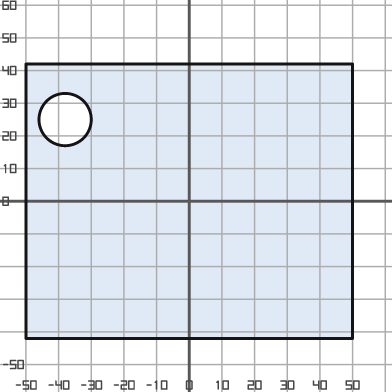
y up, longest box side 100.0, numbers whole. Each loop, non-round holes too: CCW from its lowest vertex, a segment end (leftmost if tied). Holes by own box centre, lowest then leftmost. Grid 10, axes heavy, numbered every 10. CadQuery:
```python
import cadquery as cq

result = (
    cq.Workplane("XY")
    .moveTo(-50.0, -42.0)
    .lineTo(50.0, -42.0)
    .lineTo(50.0, 42.0)
    .lineTo(-50.0, 42.0)
    .close()
    .moveTo(-38.0, 25.0)
    .circle(8.0)
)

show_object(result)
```